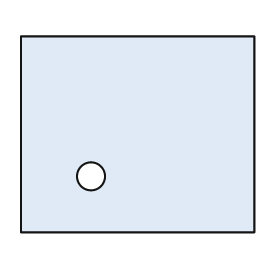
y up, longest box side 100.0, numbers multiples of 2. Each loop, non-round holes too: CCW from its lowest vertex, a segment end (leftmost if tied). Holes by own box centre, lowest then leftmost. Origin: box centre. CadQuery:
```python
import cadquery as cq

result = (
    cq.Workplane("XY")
    .moveTo(-50.0, -42.0)
    .lineTo(50.0, -42.0)
    .lineTo(50.0, 42.0)
    .lineTo(-50.0, 42.0)
    .close()
    .moveTo(-20.0, -18.0)
    .circle(6.0)
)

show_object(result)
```